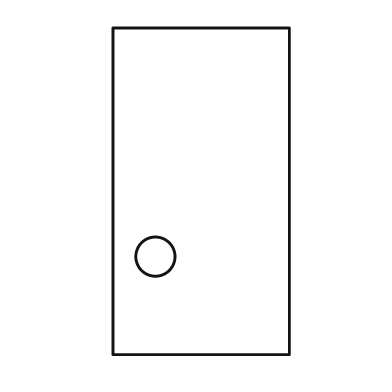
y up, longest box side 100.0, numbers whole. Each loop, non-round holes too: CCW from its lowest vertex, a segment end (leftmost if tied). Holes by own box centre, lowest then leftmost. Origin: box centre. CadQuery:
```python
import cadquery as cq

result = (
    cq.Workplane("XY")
    .moveTo(-27.0, -50.0)
    .lineTo(27.0, -50.0)
    .lineTo(27.0, 50.0)
    .lineTo(-27.0, 50.0)
    .close()
    .moveTo(-14.0, -20.0)
    .circle(6.0)
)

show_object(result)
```